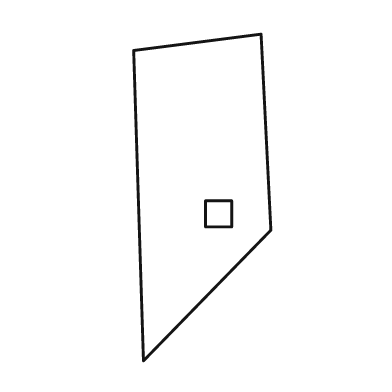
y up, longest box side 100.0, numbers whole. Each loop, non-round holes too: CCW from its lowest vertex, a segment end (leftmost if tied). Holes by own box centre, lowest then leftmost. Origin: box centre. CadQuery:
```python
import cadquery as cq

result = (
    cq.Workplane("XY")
    .moveTo(-18.0, -50.0)
    .lineTo(21.0, -10.0)
    .lineTo(18.0, 50.0)
    .lineTo(-21.0, 45.0)
    .close()
    .moveTo(1.0, -9.0)
    .lineTo(9.0, -9.0)
    .lineTo(9.0, -1.0)
    .lineTo(1.0, -1.0)
    .close()
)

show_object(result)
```